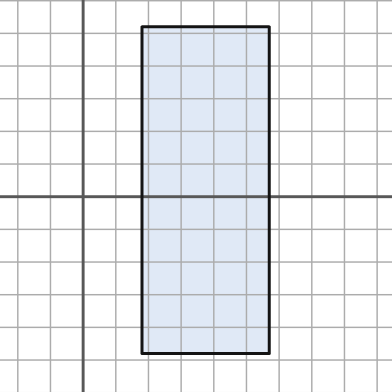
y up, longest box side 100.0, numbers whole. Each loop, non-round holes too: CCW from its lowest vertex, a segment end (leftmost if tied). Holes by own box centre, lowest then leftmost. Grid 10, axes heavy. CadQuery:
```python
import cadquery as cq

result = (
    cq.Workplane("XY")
    .moveTo(18.0, -48.0)
    .lineTo(57.0, -48.0)
    .lineTo(57.0, 52.0)
    .lineTo(18.0, 52.0)
    .close()
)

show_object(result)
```